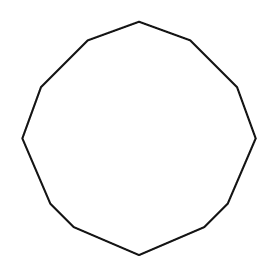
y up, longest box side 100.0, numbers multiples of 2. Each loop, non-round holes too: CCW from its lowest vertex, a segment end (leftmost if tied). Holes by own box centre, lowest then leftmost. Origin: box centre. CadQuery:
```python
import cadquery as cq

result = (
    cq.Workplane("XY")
    .moveTo(0.0, -50.0)
    .lineTo(28.0, -38.0)
    .lineTo(38.0, -28.0)
    .lineTo(50.0, 0.0)
    .lineTo(42.0, 22.0)
    .lineTo(22.0, 42.0)
    .lineTo(0.0, 50.0)
    .lineTo(-22.0, 42.0)
    .lineTo(-42.0, 22.0)
    .lineTo(-50.0, 0.0)
    .lineTo(-38.0, -28.0)
    .lineTo(-28.0, -38.0)
    .close()
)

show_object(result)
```